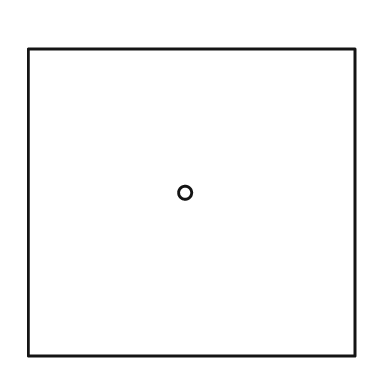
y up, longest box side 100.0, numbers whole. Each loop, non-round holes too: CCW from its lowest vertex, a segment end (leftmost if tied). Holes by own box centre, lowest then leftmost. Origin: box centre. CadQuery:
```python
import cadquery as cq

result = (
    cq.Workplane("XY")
    .moveTo(-50.0, -47.0)
    .lineTo(50.0, -47.0)
    .lineTo(50.0, 47.0)
    .lineTo(-50.0, 47.0)
    .close()
    .moveTo(-2.0, 3.0)
    .circle(2.0)
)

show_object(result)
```